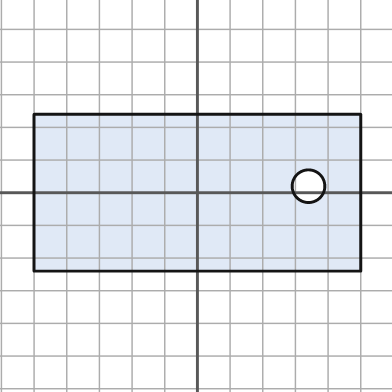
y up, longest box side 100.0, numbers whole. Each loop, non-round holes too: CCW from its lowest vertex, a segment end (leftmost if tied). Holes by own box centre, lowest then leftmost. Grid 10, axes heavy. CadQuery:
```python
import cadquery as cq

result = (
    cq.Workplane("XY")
    .moveTo(-50.0, -24.0)
    .lineTo(50.0, -24.0)
    .lineTo(50.0, 24.0)
    .lineTo(-50.0, 24.0)
    .close()
    .moveTo(34.0, 2.0)
    .circle(5.0)
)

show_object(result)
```